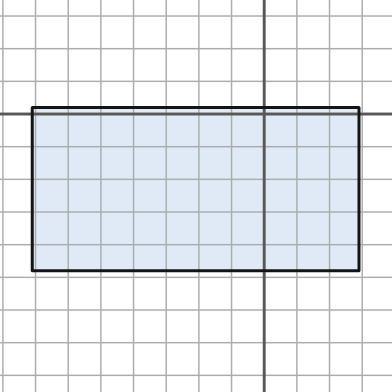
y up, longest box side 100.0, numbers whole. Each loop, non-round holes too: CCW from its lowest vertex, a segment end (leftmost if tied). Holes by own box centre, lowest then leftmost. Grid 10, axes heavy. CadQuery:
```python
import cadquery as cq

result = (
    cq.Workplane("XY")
    .moveTo(-71.0, -48.0)
    .lineTo(29.0, -48.0)
    .lineTo(29.0, 2.0)
    .lineTo(-71.0, 2.0)
    .close()
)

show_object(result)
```